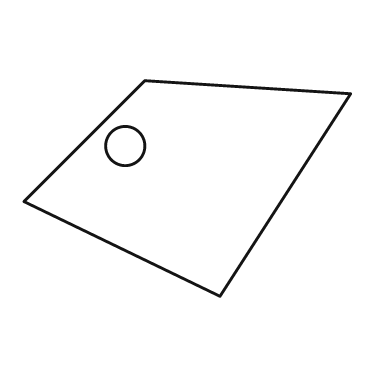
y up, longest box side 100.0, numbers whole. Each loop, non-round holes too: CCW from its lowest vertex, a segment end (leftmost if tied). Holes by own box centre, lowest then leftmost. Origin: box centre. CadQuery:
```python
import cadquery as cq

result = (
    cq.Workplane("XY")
    .moveTo(10.0, -33.0)
    .lineTo(50.0, 29.0)
    .lineTo(-13.0, 33.0)
    .lineTo(-50.0, -4.0)
    .close()
    .moveTo(-19.0, 13.0)
    .circle(6.0)
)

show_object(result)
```